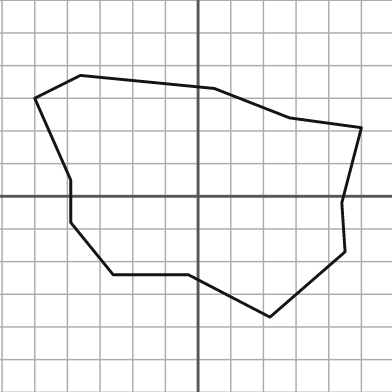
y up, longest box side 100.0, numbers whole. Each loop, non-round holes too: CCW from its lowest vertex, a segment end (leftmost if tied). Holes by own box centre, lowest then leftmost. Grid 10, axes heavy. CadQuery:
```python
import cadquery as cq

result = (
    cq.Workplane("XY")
    .moveTo(22.0, -37.0)
    .lineTo(45.0, -17.0)
    .lineTo(44.0, -2.0)
    .lineTo(50.0, 21.0)
    .lineTo(28.0, 24.0)
    .lineTo(5.0, 33.0)
    .lineTo(-36.0, 37.0)
    .lineTo(-50.0, 30.0)
    .lineTo(-39.0, 5.0)
    .lineTo(-39.0, -8.0)
    .lineTo(-26.0, -24.0)
    .lineTo(-3.0, -24.0)
    .close()
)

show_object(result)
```